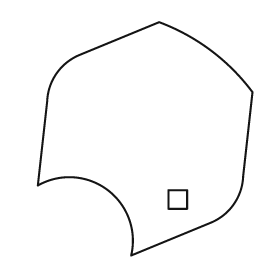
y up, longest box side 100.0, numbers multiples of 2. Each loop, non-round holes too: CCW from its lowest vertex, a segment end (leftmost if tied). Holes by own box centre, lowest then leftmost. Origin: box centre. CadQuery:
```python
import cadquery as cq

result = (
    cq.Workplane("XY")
    .moveTo(-6.0, -50.0)
    .lineTo(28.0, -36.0)
    .threePointArc((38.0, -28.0), (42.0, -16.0))
    .lineTo(46.0, 20.0)
    .threePointArc((28.0, 38.0), (6.0, 50.0))
    .lineTo(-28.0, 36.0)
    .threePointArc((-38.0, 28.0), (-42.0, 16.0))
    .lineTo(-46.0, -20.0)
    .threePointArc((-16.0, -22.0), (-6.0, -50.0))
    .close()
    .moveTo(10.0, -30.0)
    .lineTo(18.0, -30.0)
    .lineTo(18.0, -22.0)
    .lineTo(10.0, -22.0)
    .close()
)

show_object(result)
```